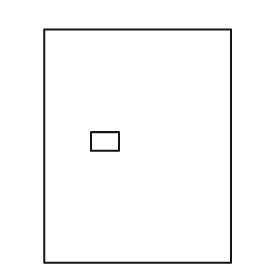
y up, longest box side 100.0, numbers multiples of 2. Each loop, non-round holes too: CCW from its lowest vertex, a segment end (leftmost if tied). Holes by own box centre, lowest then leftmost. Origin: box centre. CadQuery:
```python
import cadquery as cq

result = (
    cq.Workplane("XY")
    .moveTo(-40.0, -50.0)
    .lineTo(40.0, -50.0)
    .lineTo(40.0, 50.0)
    .lineTo(-40.0, 50.0)
    .close()
    .moveTo(-20.0, -2.0)
    .lineTo(-8.0, -2.0)
    .lineTo(-8.0, 6.0)
    .lineTo(-20.0, 6.0)
    .close()
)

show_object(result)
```